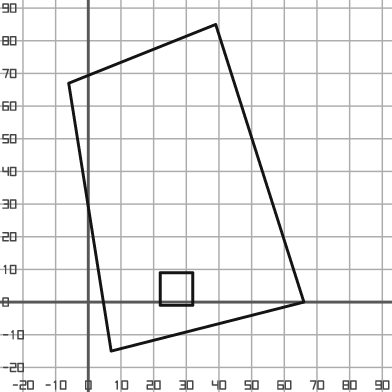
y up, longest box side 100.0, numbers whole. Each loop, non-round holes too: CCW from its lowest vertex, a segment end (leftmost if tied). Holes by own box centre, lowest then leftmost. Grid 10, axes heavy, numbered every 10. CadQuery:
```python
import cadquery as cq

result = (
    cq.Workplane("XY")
    .moveTo(7.0, -15.0)
    .lineTo(66.0, 0.0)
    .lineTo(39.0, 85.0)
    .lineTo(-6.0, 67.0)
    .close()
    .moveTo(22.0, -1.0)
    .lineTo(32.0, -1.0)
    .lineTo(32.0, 9.0)
    .lineTo(22.0, 9.0)
    .close()
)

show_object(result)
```